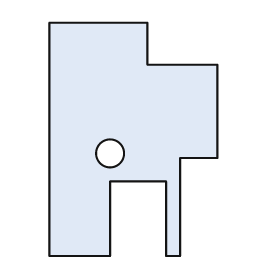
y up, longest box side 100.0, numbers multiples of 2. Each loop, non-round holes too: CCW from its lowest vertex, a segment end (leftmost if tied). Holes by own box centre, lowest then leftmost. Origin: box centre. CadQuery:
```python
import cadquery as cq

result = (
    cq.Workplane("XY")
    .moveTo(-36.0, -50.0)
    .lineTo(-10.0, -50.0)
    .lineTo(-10.0, -18.0)
    .lineTo(14.0, -18.0)
    .lineTo(14.0, -50.0)
    .lineTo(20.0, -50.0)
    .lineTo(20.0, -8.0)
    .lineTo(36.0, -8.0)
    .lineTo(36.0, 32.0)
    .lineTo(6.0, 32.0)
    .lineTo(6.0, 50.0)
    .lineTo(-36.0, 50.0)
    .close()
    .moveTo(-10.0, -6.0)
    .circle(6.0)
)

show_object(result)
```